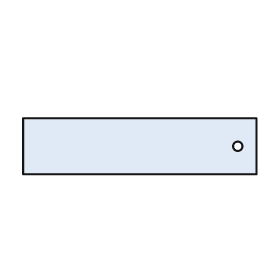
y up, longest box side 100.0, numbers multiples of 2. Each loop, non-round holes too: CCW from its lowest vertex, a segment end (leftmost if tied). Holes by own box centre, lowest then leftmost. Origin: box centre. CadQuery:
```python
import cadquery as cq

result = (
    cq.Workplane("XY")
    .moveTo(-50.0, -12.0)
    .lineTo(50.0, -12.0)
    .lineTo(50.0, 12.0)
    .lineTo(-50.0, 12.0)
    .close()
    .moveTo(42.0, 0.0)
    .circle(2.0)
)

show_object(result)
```